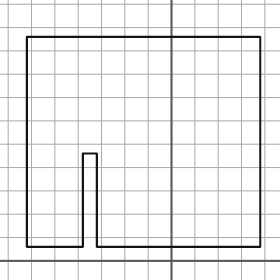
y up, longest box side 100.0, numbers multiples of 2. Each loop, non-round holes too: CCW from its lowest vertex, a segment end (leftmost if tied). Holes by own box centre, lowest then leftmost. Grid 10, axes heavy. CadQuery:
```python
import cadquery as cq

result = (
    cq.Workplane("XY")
    .moveTo(-62.0, 6.0)
    .lineTo(-38.0, 6.0)
    .lineTo(-38.0, 46.0)
    .lineTo(-32.0, 46.0)
    .lineTo(-32.0, 6.0)
    .lineTo(38.0, 6.0)
    .lineTo(38.0, 96.0)
    .lineTo(-62.0, 96.0)
    .close()
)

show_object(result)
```